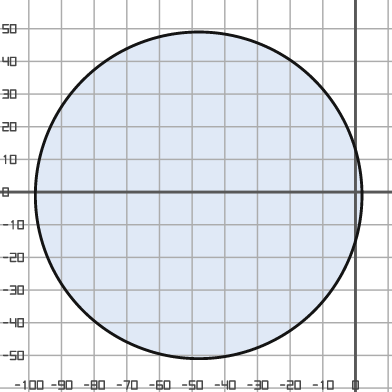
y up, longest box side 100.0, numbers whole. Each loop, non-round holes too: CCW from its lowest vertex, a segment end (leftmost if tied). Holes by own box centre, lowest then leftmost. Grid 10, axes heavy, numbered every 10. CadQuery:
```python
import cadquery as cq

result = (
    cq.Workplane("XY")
    .moveTo(-48.0, -1.0)
    .circle(50.0)
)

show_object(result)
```